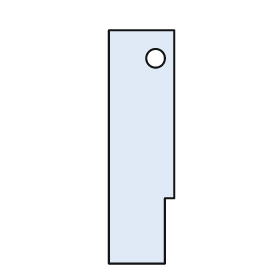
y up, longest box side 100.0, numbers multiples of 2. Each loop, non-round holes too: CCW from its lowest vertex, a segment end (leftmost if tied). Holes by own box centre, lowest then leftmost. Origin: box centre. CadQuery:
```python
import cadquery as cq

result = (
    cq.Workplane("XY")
    .moveTo(-14.0, -50.0)
    .lineTo(10.0, -50.0)
    .lineTo(10.0, -22.0)
    .lineTo(14.0, -22.0)
    .lineTo(14.0, 50.0)
    .lineTo(-14.0, 50.0)
    .close()
    .moveTo(6.0, 38.0)
    .circle(4.0)
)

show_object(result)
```